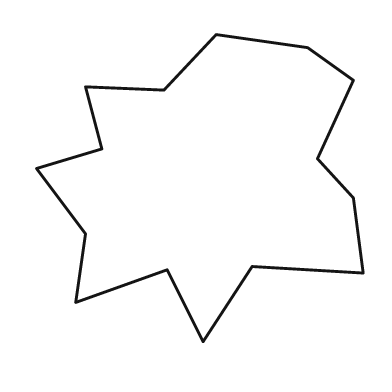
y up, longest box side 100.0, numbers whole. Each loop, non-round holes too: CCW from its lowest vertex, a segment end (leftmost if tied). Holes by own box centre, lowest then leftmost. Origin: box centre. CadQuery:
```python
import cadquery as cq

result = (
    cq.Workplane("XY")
    .moveTo(1.0, -47.0)
    .lineTo(16.0, -24.0)
    .lineTo(50.0, -26.0)
    .lineTo(47.0, -3.0)
    .lineTo(36.0, 9.0)
    .lineTo(47.0, 33.0)
    .lineTo(33.0, 43.0)
    .lineTo(5.0, 47.0)
    .lineTo(-11.0, 30.0)
    .lineTo(-35.0, 31.0)
    .lineTo(-30.0, 12.0)
    .lineTo(-50.0, 6.0)
    .lineTo(-35.0, -14.0)
    .lineTo(-38.0, -35.0)
    .lineTo(-10.0, -25.0)
    .close()
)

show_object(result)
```